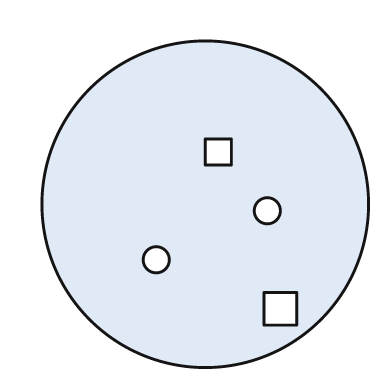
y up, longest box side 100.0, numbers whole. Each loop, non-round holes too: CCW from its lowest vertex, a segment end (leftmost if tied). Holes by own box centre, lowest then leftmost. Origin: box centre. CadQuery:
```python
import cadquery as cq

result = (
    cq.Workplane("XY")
    .moveTo(0.0, 0.0)
    .circle(50.0)
    .moveTo(18.0, -37.0)
    .lineTo(28.0, -37.0)
    .lineTo(28.0, -27.0)
    .lineTo(18.0, -27.0)
    .close()
    .moveTo(-15.0, -17.0)
    .circle(4.0)
    .moveTo(19.0, -2.0)
    .circle(4.0)
    .moveTo(0.0, 12.0)
    .lineTo(8.0, 12.0)
    .lineTo(8.0, 20.0)
    .lineTo(0.0, 20.0)
    .close()
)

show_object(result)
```